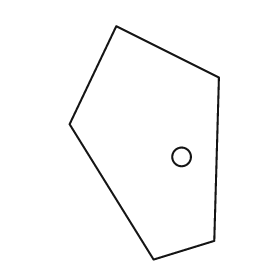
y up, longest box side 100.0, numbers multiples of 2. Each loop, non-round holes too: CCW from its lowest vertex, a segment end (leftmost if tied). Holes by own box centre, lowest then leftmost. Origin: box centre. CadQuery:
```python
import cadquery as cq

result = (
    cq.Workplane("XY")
    .moveTo(4.0, -50.0)
    .lineTo(30.0, -42.0)
    .lineTo(32.0, 28.0)
    .lineTo(-12.0, 50.0)
    .lineTo(-32.0, 8.0)
    .close()
    .moveTo(16.0, -6.0)
    .circle(4.0)
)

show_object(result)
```